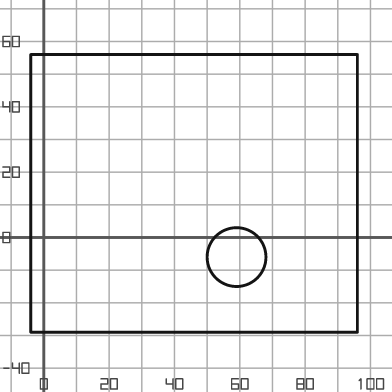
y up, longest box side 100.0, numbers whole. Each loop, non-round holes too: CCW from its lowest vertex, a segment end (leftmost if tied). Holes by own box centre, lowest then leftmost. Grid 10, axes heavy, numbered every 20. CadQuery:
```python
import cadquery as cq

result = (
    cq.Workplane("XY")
    .moveTo(-4.0, -29.0)
    .lineTo(96.0, -29.0)
    .lineTo(96.0, 56.0)
    .lineTo(-4.0, 56.0)
    .close()
    .moveTo(59.0, -6.0)
    .circle(9.0)
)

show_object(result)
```